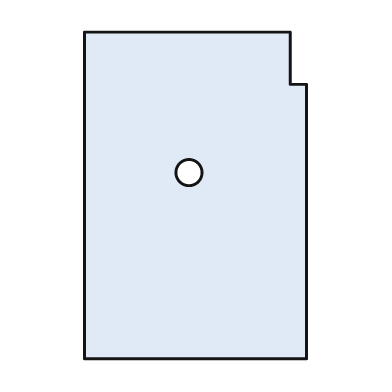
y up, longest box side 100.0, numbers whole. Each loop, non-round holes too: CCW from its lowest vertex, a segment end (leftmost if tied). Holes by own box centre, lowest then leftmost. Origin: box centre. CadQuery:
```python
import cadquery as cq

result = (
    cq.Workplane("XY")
    .moveTo(-34.0, -50.0)
    .lineTo(34.0, -50.0)
    .lineTo(34.0, 34.0)
    .lineTo(29.0, 34.0)
    .lineTo(29.0, 50.0)
    .lineTo(-34.0, 50.0)
    .close()
    .moveTo(-2.0, 7.0)
    .circle(4.0)
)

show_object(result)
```